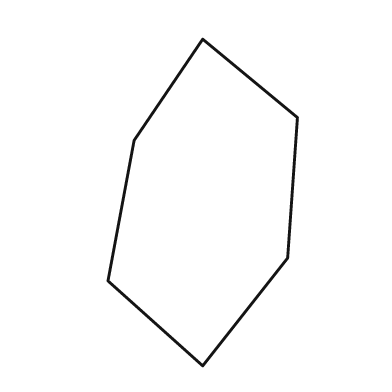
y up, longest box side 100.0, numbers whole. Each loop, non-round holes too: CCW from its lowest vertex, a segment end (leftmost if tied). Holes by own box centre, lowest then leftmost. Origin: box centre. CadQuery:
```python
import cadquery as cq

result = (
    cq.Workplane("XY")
    .moveTo(0.0, -50.0)
    .lineTo(26.0, -17.0)
    .lineTo(29.0, 26.0)
    .lineTo(0.0, 50.0)
    .lineTo(-21.0, 19.0)
    .lineTo(-29.0, -24.0)
    .close()
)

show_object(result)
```